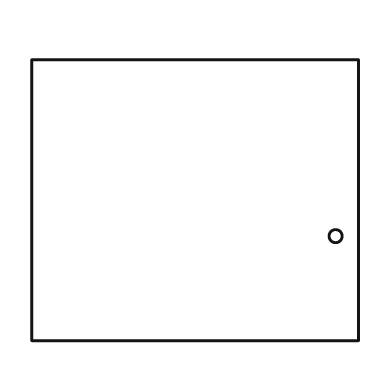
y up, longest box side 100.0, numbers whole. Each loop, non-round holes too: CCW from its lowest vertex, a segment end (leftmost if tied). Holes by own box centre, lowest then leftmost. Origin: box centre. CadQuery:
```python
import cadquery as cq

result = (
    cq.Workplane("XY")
    .moveTo(-50.0, -43.0)
    .lineTo(50.0, -43.0)
    .lineTo(50.0, 43.0)
    .lineTo(-50.0, 43.0)
    .close()
    .moveTo(43.0, -11.0)
    .circle(2.0)
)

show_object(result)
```